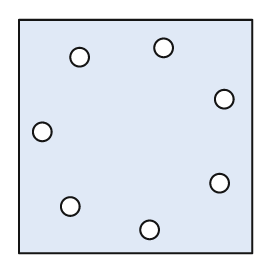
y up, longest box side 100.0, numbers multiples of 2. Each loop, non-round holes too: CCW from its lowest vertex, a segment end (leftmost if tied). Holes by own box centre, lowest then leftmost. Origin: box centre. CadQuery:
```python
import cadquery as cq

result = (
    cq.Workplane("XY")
    .moveTo(-50.0, -50.0)
    .lineTo(50.0, -50.0)
    .lineTo(50.0, 50.0)
    .lineTo(-50.0, 50.0)
    .close()
    .moveTo(6.0, -40.0)
    .circle(4.0)
    .moveTo(-28.0, -30.0)
    .circle(4.0)
    .moveTo(36.0, -20.0)
    .circle(4.0)
    .moveTo(-40.0, 2.0)
    .circle(4.0)
    .moveTo(38.0, 16.0)
    .circle(4.0)
    .moveTo(-24.0, 34.0)
    .circle(4.0)
    .moveTo(12.0, 38.0)
    .circle(4.0)
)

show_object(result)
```